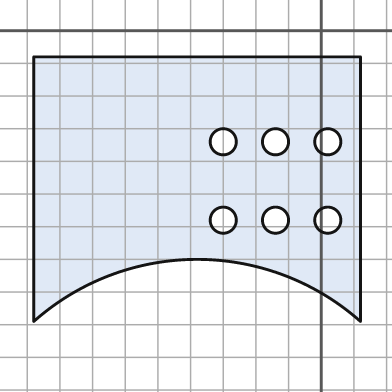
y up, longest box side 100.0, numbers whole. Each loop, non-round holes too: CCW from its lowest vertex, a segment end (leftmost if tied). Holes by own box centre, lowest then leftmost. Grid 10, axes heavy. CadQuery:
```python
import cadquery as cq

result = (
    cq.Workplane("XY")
    .moveTo(-88.0, -89.0)
    .threePointArc((-38.0, -70.0), (12.0, -89.0))
    .lineTo(12.0, -8.0)
    .lineTo(-88.0, -8.0)
    .close()
    .moveTo(-30.0, -58.0)
    .circle(4.0)
    .moveTo(-14.0, -58.0)
    .circle(4.0)
    .moveTo(2.0, -58.0)
    .circle(4.0)
    .moveTo(-30.0, -34.0)
    .circle(4.0)
    .moveTo(-14.0, -34.0)
    .circle(4.0)
    .moveTo(2.0, -34.0)
    .circle(4.0)
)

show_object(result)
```